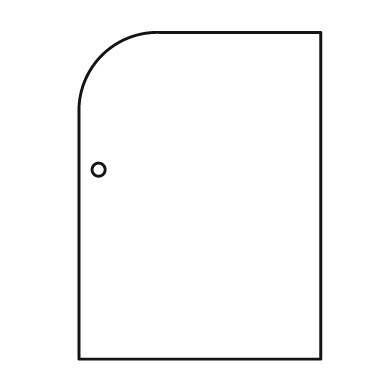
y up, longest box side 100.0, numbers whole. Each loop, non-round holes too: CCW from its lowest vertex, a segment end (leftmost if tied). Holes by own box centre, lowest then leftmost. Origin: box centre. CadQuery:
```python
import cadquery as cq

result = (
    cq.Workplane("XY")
    .moveTo(-37.0, -50.0)
    .lineTo(37.0, -50.0)
    .lineTo(37.0, 50.0)
    .lineTo(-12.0, 50.0)
    .threePointArc((-30.0, 43.0), (-37.0, 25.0))
    .close()
    .moveTo(-31.0, 8.0)
    .circle(2.0)
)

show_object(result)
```